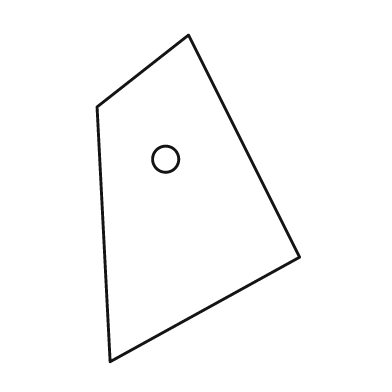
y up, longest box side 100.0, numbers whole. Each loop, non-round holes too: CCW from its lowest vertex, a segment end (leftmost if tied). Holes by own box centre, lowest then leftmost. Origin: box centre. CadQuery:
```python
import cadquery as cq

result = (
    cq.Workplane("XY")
    .moveTo(-27.0, -50.0)
    .lineTo(31.0, -18.0)
    .lineTo(-3.0, 50.0)
    .lineTo(-31.0, 28.0)
    .close()
    .moveTo(-10.0, 12.0)
    .circle(4.0)
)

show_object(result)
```